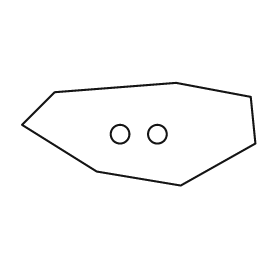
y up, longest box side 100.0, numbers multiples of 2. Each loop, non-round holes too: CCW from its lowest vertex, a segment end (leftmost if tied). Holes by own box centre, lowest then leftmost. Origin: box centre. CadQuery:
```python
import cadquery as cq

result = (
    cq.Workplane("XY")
    .moveTo(18.0, -22.0)
    .lineTo(50.0, -4.0)
    .lineTo(48.0, 16.0)
    .lineTo(16.0, 22.0)
    .lineTo(-36.0, 18.0)
    .lineTo(-50.0, 4.0)
    .lineTo(-18.0, -16.0)
    .close()
    .moveTo(-8.0, 0.0)
    .circle(4.0)
    .moveTo(8.0, 0.0)
    .circle(4.0)
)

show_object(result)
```